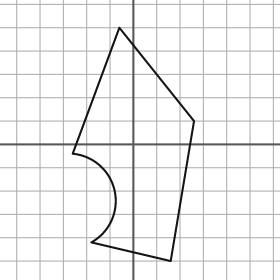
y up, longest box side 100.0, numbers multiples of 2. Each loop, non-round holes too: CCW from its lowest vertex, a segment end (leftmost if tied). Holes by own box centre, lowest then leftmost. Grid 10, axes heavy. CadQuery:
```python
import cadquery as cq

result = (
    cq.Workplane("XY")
    .moveTo(16.0, -50.0)
    .lineTo(26.0, 10.0)
    .lineTo(-6.0, 50.0)
    .lineTo(-26.0, -4.0)
    .threePointArc((-8.0, -20.0), (-18.0, -42.0))
    .close()
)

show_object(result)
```